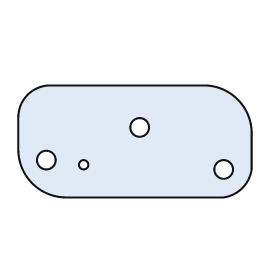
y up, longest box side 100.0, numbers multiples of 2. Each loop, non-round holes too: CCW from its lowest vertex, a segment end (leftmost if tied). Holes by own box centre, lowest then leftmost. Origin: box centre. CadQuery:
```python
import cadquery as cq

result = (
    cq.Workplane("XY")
    .moveTo(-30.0, -24.0)
    .lineTo(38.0, -24.0)
    .threePointArc((46.0, -20.0), (50.0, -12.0))
    .lineTo(50.0, 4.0)
    .threePointArc((44.0, 18.0), (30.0, 24.0))
    .lineTo(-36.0, 24.0)
    .threePointArc((-46.0, 20.0), (-50.0, 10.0))
    .lineTo(-50.0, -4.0)
    .threePointArc((-44.0, -18.0), (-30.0, -24.0))
    .close()
    .moveTo(38.0, -12.0)
    .circle(4.0)
    .moveTo(-22.0, -10.0)
    .circle(2.0)
    .moveTo(-38.0, -8.0)
    .circle(4.0)
    .moveTo(2.0, 6.0)
    .circle(4.0)
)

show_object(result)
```